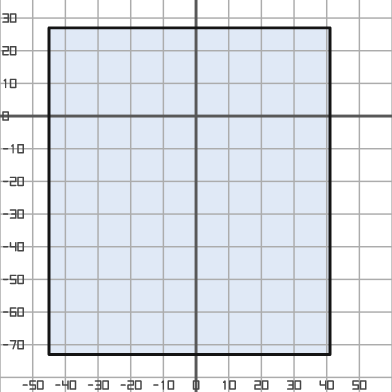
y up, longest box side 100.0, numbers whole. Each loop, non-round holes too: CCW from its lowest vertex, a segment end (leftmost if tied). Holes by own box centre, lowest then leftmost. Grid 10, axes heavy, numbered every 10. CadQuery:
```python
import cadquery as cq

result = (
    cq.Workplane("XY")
    .moveTo(-45.0, -73.0)
    .lineTo(41.0, -73.0)
    .lineTo(41.0, 27.0)
    .lineTo(-45.0, 27.0)
    .close()
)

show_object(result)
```